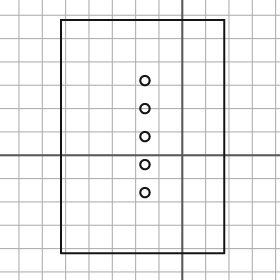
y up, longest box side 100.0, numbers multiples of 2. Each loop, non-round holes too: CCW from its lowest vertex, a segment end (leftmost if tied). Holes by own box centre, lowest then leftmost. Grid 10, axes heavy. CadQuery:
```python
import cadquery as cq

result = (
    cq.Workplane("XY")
    .moveTo(-52.0, -42.0)
    .lineTo(18.0, -42.0)
    .lineTo(18.0, 58.0)
    .lineTo(-52.0, 58.0)
    .close()
    .moveTo(-16.0, -16.0)
    .circle(2.0)
    .moveTo(-16.0, -4.0)
    .circle(2.0)
    .moveTo(-16.0, 8.0)
    .circle(2.0)
    .moveTo(-16.0, 20.0)
    .circle(2.0)
    .moveTo(-16.0, 32.0)
    .circle(2.0)
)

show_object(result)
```